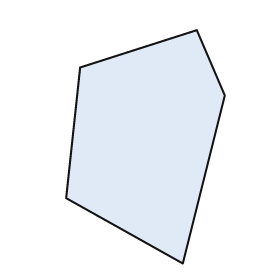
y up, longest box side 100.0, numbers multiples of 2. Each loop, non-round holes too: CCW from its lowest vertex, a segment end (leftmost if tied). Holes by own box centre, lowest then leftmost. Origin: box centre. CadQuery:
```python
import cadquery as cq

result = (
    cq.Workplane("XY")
    .moveTo(16.0, -50.0)
    .lineTo(34.0, 22.0)
    .lineTo(22.0, 50.0)
    .lineTo(-28.0, 34.0)
    .lineTo(-34.0, -22.0)
    .close()
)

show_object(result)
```